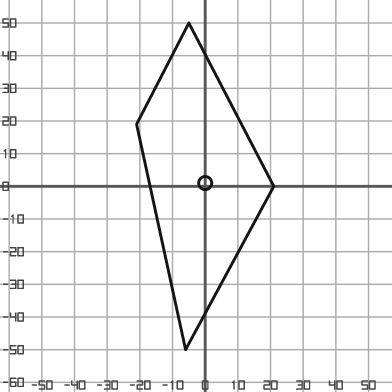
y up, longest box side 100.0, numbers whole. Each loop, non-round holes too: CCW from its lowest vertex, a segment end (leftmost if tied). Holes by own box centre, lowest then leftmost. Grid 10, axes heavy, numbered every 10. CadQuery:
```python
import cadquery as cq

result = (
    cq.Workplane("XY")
    .moveTo(-6.0, -50.0)
    .lineTo(21.0, 0.0)
    .lineTo(-5.0, 50.0)
    .lineTo(-21.0, 19.0)
    .close()
    .moveTo(0.0, 1.0)
    .circle(2.0)
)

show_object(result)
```